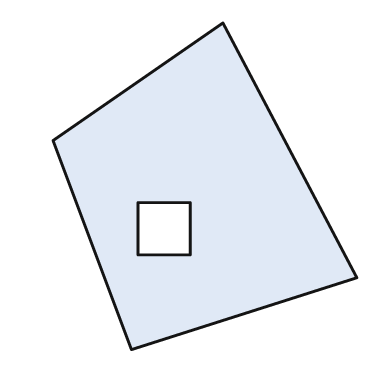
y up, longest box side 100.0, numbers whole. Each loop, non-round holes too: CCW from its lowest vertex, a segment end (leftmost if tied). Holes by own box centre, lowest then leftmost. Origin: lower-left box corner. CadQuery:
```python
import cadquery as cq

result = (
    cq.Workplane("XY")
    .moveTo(24.0, 0.0)
    .lineTo(93.0, 22.0)
    .lineTo(52.0, 100.0)
    .lineTo(0.0, 64.0)
    .close()
    .moveTo(26.0, 29.0)
    .lineTo(42.0, 29.0)
    .lineTo(42.0, 45.0)
    .lineTo(26.0, 45.0)
    .close()
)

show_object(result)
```